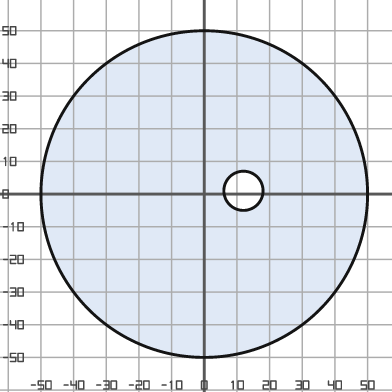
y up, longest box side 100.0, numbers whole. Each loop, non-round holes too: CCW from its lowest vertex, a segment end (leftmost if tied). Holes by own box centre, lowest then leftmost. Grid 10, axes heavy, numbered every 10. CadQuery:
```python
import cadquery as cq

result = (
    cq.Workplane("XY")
    .moveTo(0.0, 0.0)
    .circle(50.0)
    .moveTo(12.0, 1.0)
    .circle(6.0)
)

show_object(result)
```